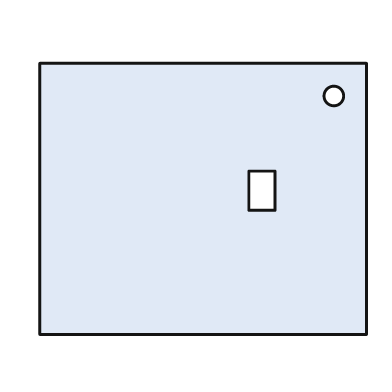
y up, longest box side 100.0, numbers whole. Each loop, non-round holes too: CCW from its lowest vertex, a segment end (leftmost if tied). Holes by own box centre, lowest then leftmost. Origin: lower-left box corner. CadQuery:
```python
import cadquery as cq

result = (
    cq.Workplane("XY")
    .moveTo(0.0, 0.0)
    .lineTo(100.0, 0.0)
    .lineTo(100.0, 83.0)
    .lineTo(0.0, 83.0)
    .close()
    .moveTo(64.0, 38.0)
    .lineTo(72.0, 38.0)
    .lineTo(72.0, 50.0)
    .lineTo(64.0, 50.0)
    .close()
    .moveTo(90.0, 73.0)
    .circle(3.0)
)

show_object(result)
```